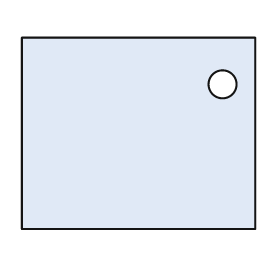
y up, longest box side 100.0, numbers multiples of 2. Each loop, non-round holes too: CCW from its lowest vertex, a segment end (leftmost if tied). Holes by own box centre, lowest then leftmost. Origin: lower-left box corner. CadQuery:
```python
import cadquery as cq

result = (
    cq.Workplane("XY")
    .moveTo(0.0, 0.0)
    .lineTo(100.0, 0.0)
    .lineTo(100.0, 82.0)
    .lineTo(0.0, 82.0)
    .close()
    .moveTo(86.0, 62.0)
    .circle(6.0)
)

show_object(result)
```